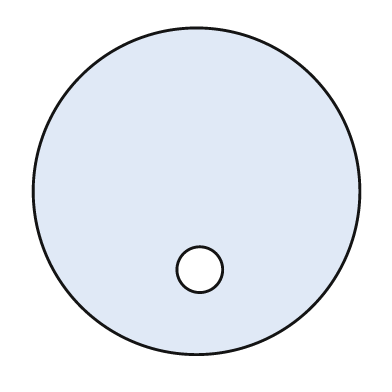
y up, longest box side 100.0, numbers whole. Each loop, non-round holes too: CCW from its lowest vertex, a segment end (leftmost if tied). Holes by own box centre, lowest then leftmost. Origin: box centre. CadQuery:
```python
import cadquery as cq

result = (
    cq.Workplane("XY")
    .moveTo(0.0, 0.0)
    .circle(50.0)
    .moveTo(1.0, -24.0)
    .circle(7.0)
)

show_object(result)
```